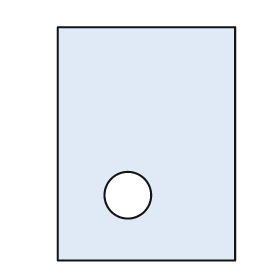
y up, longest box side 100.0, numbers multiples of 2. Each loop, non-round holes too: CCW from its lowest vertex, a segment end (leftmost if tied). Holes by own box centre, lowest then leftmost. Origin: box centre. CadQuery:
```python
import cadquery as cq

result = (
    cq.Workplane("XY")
    .moveTo(-38.0, -50.0)
    .lineTo(38.0, -50.0)
    .lineTo(38.0, 50.0)
    .lineTo(-38.0, 50.0)
    .close()
    .moveTo(-8.0, -22.0)
    .circle(10.0)
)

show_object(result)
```